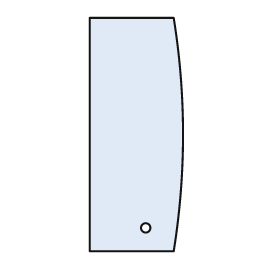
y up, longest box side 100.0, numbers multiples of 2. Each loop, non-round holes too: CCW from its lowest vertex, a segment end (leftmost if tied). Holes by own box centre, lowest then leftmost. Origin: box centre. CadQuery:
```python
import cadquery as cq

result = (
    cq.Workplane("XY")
    .moveTo(-20.0, -50.0)
    .lineTo(16.0, -50.0)
    .threePointArc((20.0, 0.0), (16.0, 50.0))
    .lineTo(-20.0, 50.0)
    .close()
    .moveTo(4.0, -40.0)
    .circle(2.0)
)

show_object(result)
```